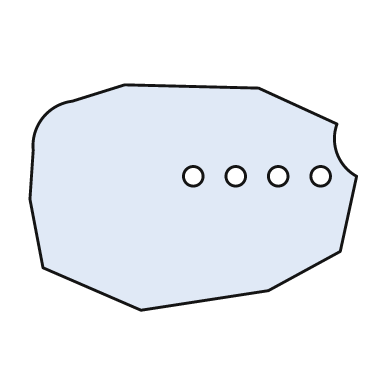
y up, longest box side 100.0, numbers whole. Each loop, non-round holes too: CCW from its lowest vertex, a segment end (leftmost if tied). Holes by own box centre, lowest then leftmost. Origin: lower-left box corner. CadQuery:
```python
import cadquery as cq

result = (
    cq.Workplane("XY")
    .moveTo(34.0, 0.0)
    .lineTo(73.0, 6.0)
    .lineTo(95.0, 18.0)
    .lineTo(100.0, 41.0)
    .threePointArc((94.0, 48.0), (94.0, 57.0))
    .lineTo(70.0, 68.0)
    .lineTo(29.0, 69.0)
    .lineTo(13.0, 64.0)
    .threePointArc((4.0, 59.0), (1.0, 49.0))
    .lineTo(0.0, 34.0)
    .lineTo(4.0, 13.0)
    .close()
    .moveTo(50.0, 41.0)
    .circle(3.0)
    .moveTo(63.0, 41.0)
    .circle(3.0)
    .moveTo(76.0, 41.0)
    .circle(3.0)
    .moveTo(89.0, 41.0)
    .circle(3.0)
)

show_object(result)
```